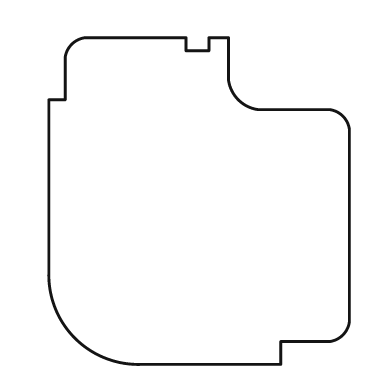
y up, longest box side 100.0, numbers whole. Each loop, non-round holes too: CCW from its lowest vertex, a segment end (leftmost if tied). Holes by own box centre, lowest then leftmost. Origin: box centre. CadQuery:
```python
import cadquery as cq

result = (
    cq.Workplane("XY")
    .moveTo(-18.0, -50.0)
    .lineTo(25.0, -50.0)
    .lineTo(25.0, -43.0)
    .lineTo(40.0, -43.0)
    .threePointArc((44.0, -41.0), (46.0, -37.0))
    .lineTo(46.0, 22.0)
    .threePointArc((44.0, 26.0), (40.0, 28.0))
    .lineTo(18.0, 28.0)
    .threePointArc((12.0, 31.0), (9.0, 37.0))
    .lineTo(9.0, 50.0)
    .lineTo(3.0, 50.0)
    .lineTo(3.0, 46.0)
    .lineTo(-4.0, 46.0)
    .lineTo(-4.0, 50.0)
    .lineTo(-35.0, 50.0)
    .threePointArc((-39.0, 48.0), (-41.0, 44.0))
    .lineTo(-41.0, 31.0)
    .lineTo(-46.0, 31.0)
    .lineTo(-46.0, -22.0)
    .threePointArc((-38.0, -42.0), (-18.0, -50.0))
    .close()
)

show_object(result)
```